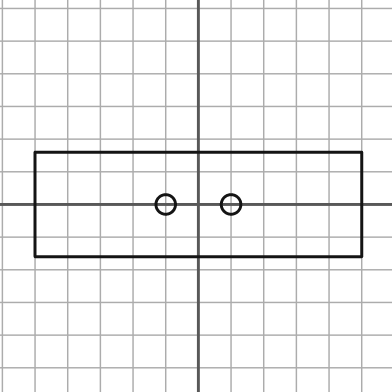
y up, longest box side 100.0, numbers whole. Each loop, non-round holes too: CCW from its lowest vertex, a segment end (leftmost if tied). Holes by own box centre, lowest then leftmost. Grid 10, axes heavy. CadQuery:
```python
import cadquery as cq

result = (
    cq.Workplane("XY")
    .moveTo(-50.0, -16.0)
    .lineTo(50.0, -16.0)
    .lineTo(50.0, 16.0)
    .lineTo(-50.0, 16.0)
    .close()
    .moveTo(-10.0, 0.0)
    .circle(3.0)
    .moveTo(10.0, 0.0)
    .circle(3.0)
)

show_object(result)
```